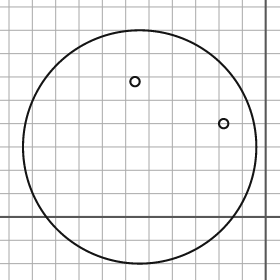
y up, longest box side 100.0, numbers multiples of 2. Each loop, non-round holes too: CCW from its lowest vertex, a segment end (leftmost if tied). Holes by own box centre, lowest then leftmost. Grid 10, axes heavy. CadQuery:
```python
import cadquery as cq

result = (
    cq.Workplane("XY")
    .moveTo(-54.0, 30.0)
    .circle(50.0)
    .moveTo(-18.0, 40.0)
    .circle(2.0)
    .moveTo(-56.0, 58.0)
    .circle(2.0)
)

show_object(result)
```